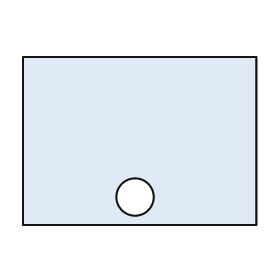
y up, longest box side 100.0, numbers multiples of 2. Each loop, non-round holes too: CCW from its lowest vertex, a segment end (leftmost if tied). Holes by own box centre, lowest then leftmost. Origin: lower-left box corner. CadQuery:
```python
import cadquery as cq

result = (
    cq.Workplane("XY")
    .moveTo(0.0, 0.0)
    .lineTo(100.0, 0.0)
    .lineTo(100.0, 72.0)
    .lineTo(0.0, 72.0)
    .close()
    .moveTo(48.0, 12.0)
    .circle(8.0)
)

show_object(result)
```